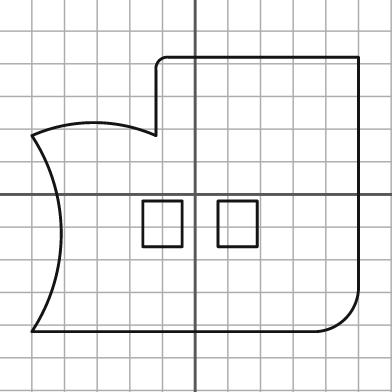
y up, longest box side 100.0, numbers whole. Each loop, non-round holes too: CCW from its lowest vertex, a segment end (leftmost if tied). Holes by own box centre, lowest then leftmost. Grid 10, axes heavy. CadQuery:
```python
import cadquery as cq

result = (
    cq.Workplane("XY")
    .moveTo(-50.0, -42.0)
    .lineTo(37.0, -42.0)
    .threePointArc((46.0, -38.0), (50.0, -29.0))
    .lineTo(50.0, 42.0)
    .lineTo(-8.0, 42.0)
    .threePointArc((-11.0, 41.0), (-12.0, 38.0))
    .lineTo(-12.0, 18.0)
    .threePointArc((-31.0, 22.0), (-50.0, 18.0))
    .threePointArc((-41.0, -12.0), (-50.0, -42.0))
    .close()
    .moveTo(-16.0, -16.0)
    .lineTo(-4.0, -16.0)
    .lineTo(-4.0, -2.0)
    .lineTo(-16.0, -2.0)
    .close()
    .moveTo(7.0, -16.0)
    .lineTo(19.0, -16.0)
    .lineTo(19.0, -2.0)
    .lineTo(7.0, -2.0)
    .close()
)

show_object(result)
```